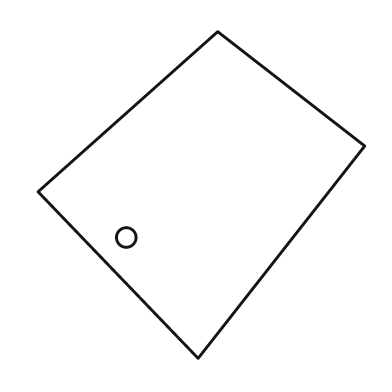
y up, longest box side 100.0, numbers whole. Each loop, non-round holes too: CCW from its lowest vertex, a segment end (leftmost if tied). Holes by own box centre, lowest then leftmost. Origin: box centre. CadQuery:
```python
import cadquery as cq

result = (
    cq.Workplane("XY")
    .moveTo(-1.0, -50.0)
    .lineTo(50.0, 15.0)
    .lineTo(5.0, 50.0)
    .lineTo(-50.0, 1.0)
    .close()
    .moveTo(-23.0, -13.0)
    .circle(3.0)
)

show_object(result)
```